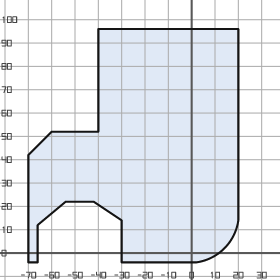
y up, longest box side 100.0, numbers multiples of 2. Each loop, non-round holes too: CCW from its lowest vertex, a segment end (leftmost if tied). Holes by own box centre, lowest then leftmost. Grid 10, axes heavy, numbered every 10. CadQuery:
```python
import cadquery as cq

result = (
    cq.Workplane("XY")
    .moveTo(-70.0, -4.0)
    .lineTo(-66.0, -4.0)
    .lineTo(-66.0, 12.0)
    .lineTo(-54.0, 22.0)
    .lineTo(-42.0, 22.0)
    .lineTo(-30.0, 14.0)
    .lineTo(-30.0, -4.0)
    .lineTo(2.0, -4.0)
    .threePointArc((14.0, 2.0), (20.0, 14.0))
    .lineTo(20.0, 96.0)
    .lineTo(-40.0, 96.0)
    .lineTo(-40.0, 52.0)
    .lineTo(-60.0, 52.0)
    .lineTo(-70.0, 42.0)
    .close()
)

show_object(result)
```